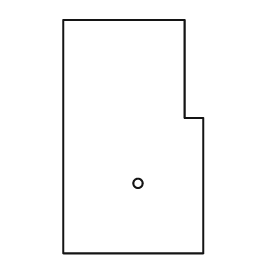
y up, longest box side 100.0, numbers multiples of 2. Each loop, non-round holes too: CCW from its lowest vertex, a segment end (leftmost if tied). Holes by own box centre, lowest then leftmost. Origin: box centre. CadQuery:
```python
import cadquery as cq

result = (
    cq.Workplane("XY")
    .moveTo(-30.0, -50.0)
    .lineTo(30.0, -50.0)
    .lineTo(30.0, 8.0)
    .lineTo(22.0, 8.0)
    .lineTo(22.0, 50.0)
    .lineTo(-30.0, 50.0)
    .close()
    .moveTo(2.0, -20.0)
    .circle(2.0)
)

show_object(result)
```